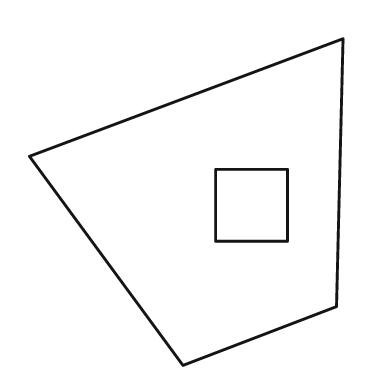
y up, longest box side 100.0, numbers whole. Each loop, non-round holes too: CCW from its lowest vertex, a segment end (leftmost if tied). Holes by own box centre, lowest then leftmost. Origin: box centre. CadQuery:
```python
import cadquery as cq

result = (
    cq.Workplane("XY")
    .moveTo(-1.0, -50.0)
    .lineTo(46.0, -32.0)
    .lineTo(48.0, 50.0)
    .lineTo(-48.0, 14.0)
    .close()
    .moveTo(9.0, -12.0)
    .lineTo(31.0, -12.0)
    .lineTo(31.0, 10.0)
    .lineTo(9.0, 10.0)
    .close()
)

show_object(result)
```